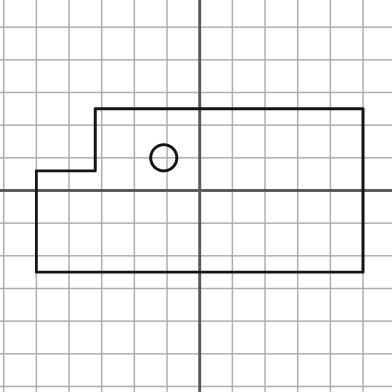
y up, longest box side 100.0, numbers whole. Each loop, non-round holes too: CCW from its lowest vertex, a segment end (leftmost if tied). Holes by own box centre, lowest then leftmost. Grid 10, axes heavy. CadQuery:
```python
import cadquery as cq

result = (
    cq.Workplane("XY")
    .moveTo(-50.0, -25.0)
    .lineTo(50.0, -25.0)
    .lineTo(50.0, 25.0)
    .lineTo(-32.0, 25.0)
    .lineTo(-32.0, 6.0)
    .lineTo(-50.0, 6.0)
    .close()
    .moveTo(-11.0, 10.0)
    .circle(4.0)
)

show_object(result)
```